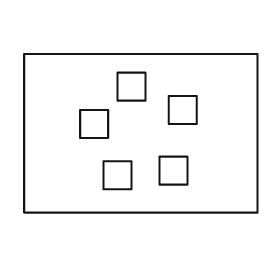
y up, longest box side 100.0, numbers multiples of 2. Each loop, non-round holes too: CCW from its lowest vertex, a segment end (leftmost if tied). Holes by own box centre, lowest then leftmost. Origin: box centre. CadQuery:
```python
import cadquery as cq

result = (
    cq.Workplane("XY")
    .moveTo(-50.0, -34.0)
    .lineTo(50.0, -34.0)
    .lineTo(50.0, 34.0)
    .lineTo(-50.0, 34.0)
    .close()
    .moveTo(-16.0, -24.0)
    .lineTo(-4.0, -24.0)
    .lineTo(-4.0, -12.0)
    .lineTo(-16.0, -12.0)
    .close()
    .moveTo(8.0, -22.0)
    .lineTo(20.0, -22.0)
    .lineTo(20.0, -10.0)
    .lineTo(8.0, -10.0)
    .close()
    .moveTo(-26.0, -2.0)
    .lineTo(-14.0, -2.0)
    .lineTo(-14.0, 10.0)
    .lineTo(-26.0, 10.0)
    .close()
    .moveTo(12.0, 4.0)
    .lineTo(24.0, 4.0)
    .lineTo(24.0, 16.0)
    .lineTo(12.0, 16.0)
    .close()
    .moveTo(-10.0, 14.0)
    .lineTo(2.0, 14.0)
    .lineTo(2.0, 26.0)
    .lineTo(-10.0, 26.0)
    .close()
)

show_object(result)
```